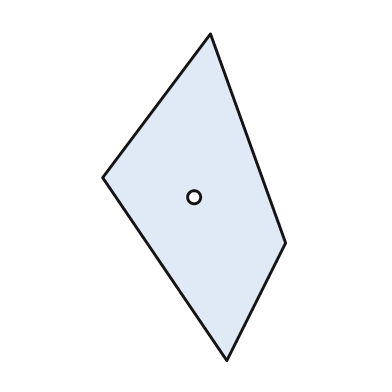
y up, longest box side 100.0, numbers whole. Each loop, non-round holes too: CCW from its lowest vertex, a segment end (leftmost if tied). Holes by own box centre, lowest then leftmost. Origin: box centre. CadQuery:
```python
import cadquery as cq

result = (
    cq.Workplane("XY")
    .moveTo(10.0, -50.0)
    .lineTo(28.0, -14.0)
    .lineTo(5.0, 50.0)
    .lineTo(-28.0, 6.0)
    .close()
    .moveTo(0.0, 0.0)
    .circle(2.0)
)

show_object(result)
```